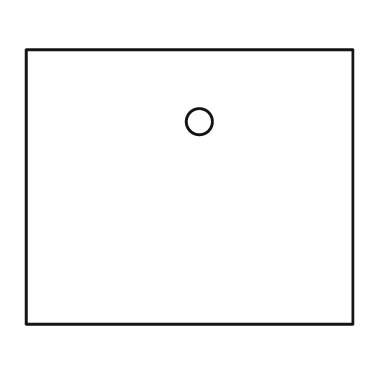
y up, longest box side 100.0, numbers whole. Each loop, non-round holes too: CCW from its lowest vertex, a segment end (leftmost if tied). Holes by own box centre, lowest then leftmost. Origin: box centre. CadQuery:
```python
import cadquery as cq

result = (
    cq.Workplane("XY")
    .moveTo(-50.0, -42.0)
    .lineTo(50.0, -42.0)
    .lineTo(50.0, 42.0)
    .lineTo(-50.0, 42.0)
    .close()
    .moveTo(3.0, 20.0)
    .circle(4.0)
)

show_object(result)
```